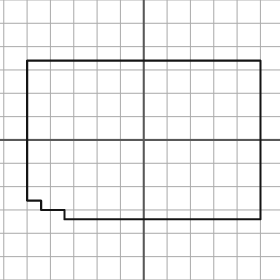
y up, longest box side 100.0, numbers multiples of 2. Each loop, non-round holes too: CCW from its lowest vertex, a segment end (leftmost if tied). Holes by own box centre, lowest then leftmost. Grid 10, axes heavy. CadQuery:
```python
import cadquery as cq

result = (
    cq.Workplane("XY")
    .moveTo(-34.0, -34.0)
    .lineTo(50.0, -34.0)
    .lineTo(50.0, 34.0)
    .lineTo(-50.0, 34.0)
    .lineTo(-50.0, -26.0)
    .lineTo(-44.0, -26.0)
    .lineTo(-44.0, -30.0)
    .lineTo(-34.0, -30.0)
    .close()
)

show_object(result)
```